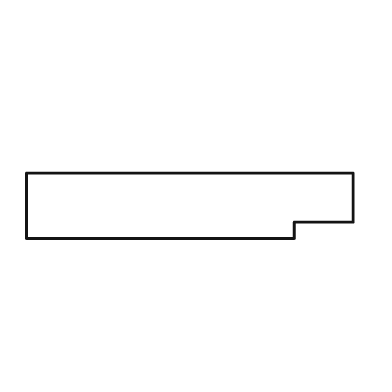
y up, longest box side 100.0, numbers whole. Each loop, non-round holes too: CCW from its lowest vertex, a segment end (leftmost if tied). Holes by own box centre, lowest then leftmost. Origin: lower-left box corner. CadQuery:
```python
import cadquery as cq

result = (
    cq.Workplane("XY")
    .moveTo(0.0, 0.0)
    .lineTo(82.0, 0.0)
    .lineTo(82.0, 5.0)
    .lineTo(100.0, 5.0)
    .lineTo(100.0, 20.0)
    .lineTo(0.0, 20.0)
    .close()
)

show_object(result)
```